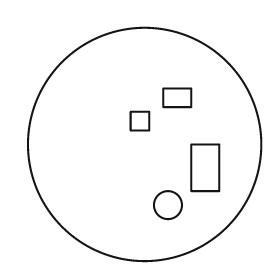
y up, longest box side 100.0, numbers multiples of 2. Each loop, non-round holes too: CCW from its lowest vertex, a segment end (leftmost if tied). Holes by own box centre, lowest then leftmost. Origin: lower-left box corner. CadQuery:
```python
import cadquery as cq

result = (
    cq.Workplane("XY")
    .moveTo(50.0, 50.0)
    .circle(50.0)
    .moveTo(60.0, 24.0)
    .circle(6.0)
    .moveTo(70.0, 30.0)
    .lineTo(82.0, 30.0)
    .lineTo(82.0, 50.0)
    .lineTo(70.0, 50.0)
    .close()
    .moveTo(44.0, 56.0)
    .lineTo(52.0, 56.0)
    .lineTo(52.0, 64.0)
    .lineTo(44.0, 64.0)
    .close()
    .moveTo(58.0, 66.0)
    .lineTo(70.0, 66.0)
    .lineTo(70.0, 74.0)
    .lineTo(58.0, 74.0)
    .close()
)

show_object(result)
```